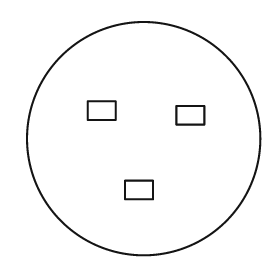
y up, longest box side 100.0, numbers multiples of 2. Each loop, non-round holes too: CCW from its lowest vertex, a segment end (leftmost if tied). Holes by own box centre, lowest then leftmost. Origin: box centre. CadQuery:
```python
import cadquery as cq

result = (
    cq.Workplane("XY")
    .moveTo(0.0, 0.0)
    .circle(50.0)
    .moveTo(-8.0, -26.0)
    .lineTo(4.0, -26.0)
    .lineTo(4.0, -18.0)
    .lineTo(-8.0, -18.0)
    .close()
    .moveTo(14.0, 6.0)
    .lineTo(26.0, 6.0)
    .lineTo(26.0, 14.0)
    .lineTo(14.0, 14.0)
    .close()
    .moveTo(-24.0, 8.0)
    .lineTo(-12.0, 8.0)
    .lineTo(-12.0, 16.0)
    .lineTo(-24.0, 16.0)
    .close()
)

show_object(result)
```